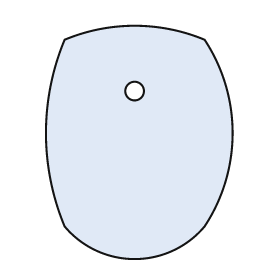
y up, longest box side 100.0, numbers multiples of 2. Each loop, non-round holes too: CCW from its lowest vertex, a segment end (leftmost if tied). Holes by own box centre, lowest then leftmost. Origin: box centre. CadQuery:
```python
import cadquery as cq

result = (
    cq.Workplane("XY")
    .moveTo(-32.0, -36.0)
    .threePointArc((-2.0, -50.0), (28.0, -36.0))
    .threePointArc((40.0, 4.0), (28.0, 44.0))
    .threePointArc((-2.0, 50.0), (-32.0, 44.0))
    .threePointArc((-40.0, 4.0), (-32.0, -36.0))
    .close()
    .moveTo(-2.0, 22.0)
    .circle(4.0)
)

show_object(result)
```